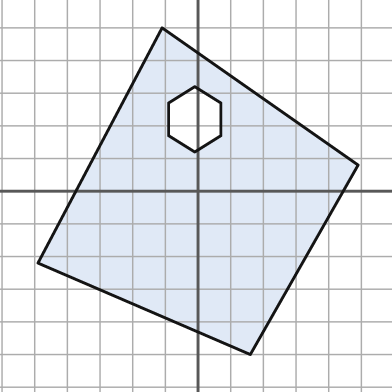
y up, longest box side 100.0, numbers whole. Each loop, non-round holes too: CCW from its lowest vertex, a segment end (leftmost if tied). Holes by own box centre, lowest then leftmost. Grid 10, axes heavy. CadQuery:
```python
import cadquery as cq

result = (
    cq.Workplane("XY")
    .moveTo(16.0, -50.0)
    .lineTo(49.0, 8.0)
    .lineTo(-11.0, 50.0)
    .lineTo(-49.0, -22.0)
    .close()
    .moveTo(-1.0, 12.0)
    .lineTo(7.0, 17.0)
    .lineTo(7.0, 27.0)
    .lineTo(-1.0, 32.0)
    .lineTo(-9.0, 27.0)
    .lineTo(-9.0, 17.0)
    .close()
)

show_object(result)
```